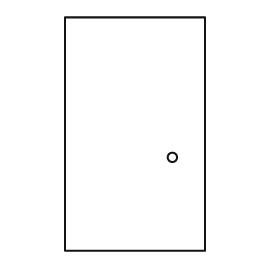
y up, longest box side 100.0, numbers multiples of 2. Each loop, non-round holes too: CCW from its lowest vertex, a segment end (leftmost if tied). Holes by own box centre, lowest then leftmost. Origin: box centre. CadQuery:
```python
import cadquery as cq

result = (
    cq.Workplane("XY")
    .moveTo(-30.0, -50.0)
    .lineTo(30.0, -50.0)
    .lineTo(30.0, 50.0)
    .lineTo(-30.0, 50.0)
    .close()
    .moveTo(16.0, -10.0)
    .circle(2.0)
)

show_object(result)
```